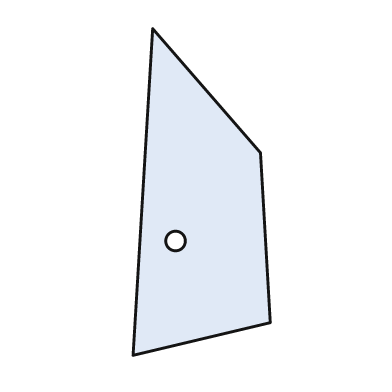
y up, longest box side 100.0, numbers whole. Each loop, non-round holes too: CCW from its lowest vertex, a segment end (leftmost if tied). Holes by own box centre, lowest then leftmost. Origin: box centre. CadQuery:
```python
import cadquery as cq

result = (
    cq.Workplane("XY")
    .moveTo(-21.0, -50.0)
    .lineTo(21.0, -40.0)
    .lineTo(18.0, 12.0)
    .lineTo(-15.0, 50.0)
    .close()
    .moveTo(-8.0, -15.0)
    .circle(3.0)
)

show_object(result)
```